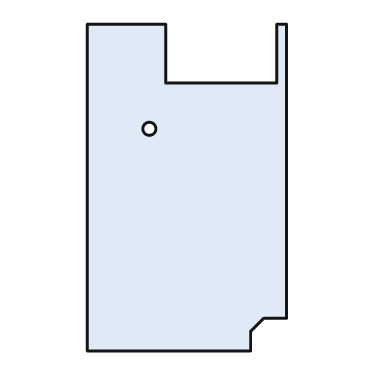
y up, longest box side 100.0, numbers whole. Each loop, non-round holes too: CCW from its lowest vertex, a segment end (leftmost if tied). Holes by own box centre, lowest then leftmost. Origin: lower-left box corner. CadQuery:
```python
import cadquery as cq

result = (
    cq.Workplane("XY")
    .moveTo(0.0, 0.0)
    .lineTo(50.0, 0.0)
    .lineTo(50.0, 6.0)
    .lineTo(54.0, 10.0)
    .lineTo(61.0, 10.0)
    .lineTo(61.0, 100.0)
    .lineTo(58.0, 100.0)
    .lineTo(58.0, 82.0)
    .lineTo(24.0, 82.0)
    .lineTo(24.0, 100.0)
    .lineTo(0.0, 100.0)
    .close()
    .moveTo(19.0, 68.0)
    .circle(2.0)
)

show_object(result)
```